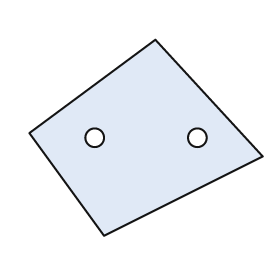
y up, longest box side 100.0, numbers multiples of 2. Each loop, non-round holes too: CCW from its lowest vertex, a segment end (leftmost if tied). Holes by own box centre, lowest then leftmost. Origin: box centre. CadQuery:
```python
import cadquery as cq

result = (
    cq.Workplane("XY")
    .moveTo(-18.0, -42.0)
    .lineTo(50.0, -8.0)
    .lineTo(4.0, 42.0)
    .lineTo(-50.0, 2.0)
    .close()
    .moveTo(-22.0, 0.0)
    .circle(4.0)
    .moveTo(22.0, 0.0)
    .circle(4.0)
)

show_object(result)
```